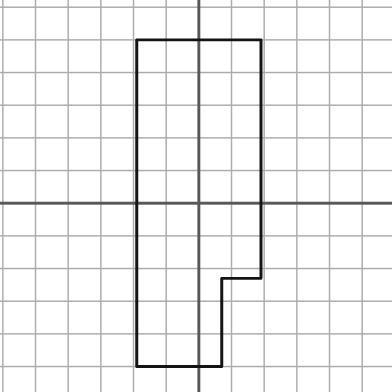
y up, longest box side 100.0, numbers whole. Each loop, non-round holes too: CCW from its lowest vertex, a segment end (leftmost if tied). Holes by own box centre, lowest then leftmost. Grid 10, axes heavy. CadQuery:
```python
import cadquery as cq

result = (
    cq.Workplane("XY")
    .moveTo(-19.0, -50.0)
    .lineTo(7.0, -50.0)
    .lineTo(7.0, -23.0)
    .lineTo(19.0, -23.0)
    .lineTo(19.0, 50.0)
    .lineTo(-19.0, 50.0)
    .close()
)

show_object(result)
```